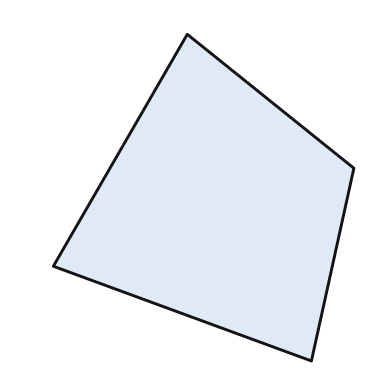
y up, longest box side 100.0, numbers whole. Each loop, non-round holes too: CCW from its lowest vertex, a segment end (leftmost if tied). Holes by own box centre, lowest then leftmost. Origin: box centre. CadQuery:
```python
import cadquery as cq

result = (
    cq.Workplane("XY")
    .moveTo(33.0, -50.0)
    .lineTo(46.0, 9.0)
    .lineTo(-5.0, 50.0)
    .lineTo(-46.0, -21.0)
    .close()
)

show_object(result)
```